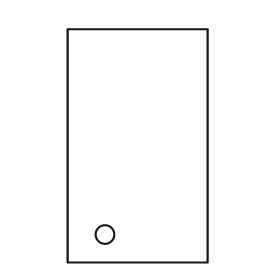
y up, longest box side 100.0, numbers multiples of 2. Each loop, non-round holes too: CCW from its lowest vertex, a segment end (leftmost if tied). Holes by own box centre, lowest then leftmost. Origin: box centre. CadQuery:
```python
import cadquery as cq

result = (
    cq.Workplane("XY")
    .moveTo(-30.0, -50.0)
    .lineTo(30.0, -50.0)
    .lineTo(30.0, 50.0)
    .lineTo(-30.0, 50.0)
    .close()
    .moveTo(-14.0, -38.0)
    .circle(4.0)
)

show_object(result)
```